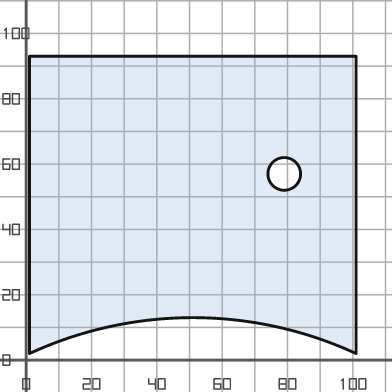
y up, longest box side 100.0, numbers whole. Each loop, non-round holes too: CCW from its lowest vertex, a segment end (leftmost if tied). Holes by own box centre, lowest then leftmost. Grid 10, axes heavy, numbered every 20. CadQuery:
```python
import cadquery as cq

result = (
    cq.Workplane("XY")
    .moveTo(1.0, 2.0)
    .threePointArc((51.0, 13.0), (101.0, 2.0))
    .lineTo(101.0, 93.0)
    .lineTo(1.0, 93.0)
    .close()
    .moveTo(79.0, 57.0)
    .circle(5.0)
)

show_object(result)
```